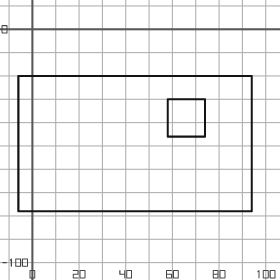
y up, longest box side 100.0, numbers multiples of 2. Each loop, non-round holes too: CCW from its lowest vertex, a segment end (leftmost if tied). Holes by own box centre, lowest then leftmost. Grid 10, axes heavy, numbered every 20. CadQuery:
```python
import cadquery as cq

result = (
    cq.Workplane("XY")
    .moveTo(-6.0, -78.0)
    .lineTo(94.0, -78.0)
    .lineTo(94.0, -20.0)
    .lineTo(-6.0, -20.0)
    .close()
    .moveTo(58.0, -46.0)
    .lineTo(74.0, -46.0)
    .lineTo(74.0, -30.0)
    .lineTo(58.0, -30.0)
    .close()
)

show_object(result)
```